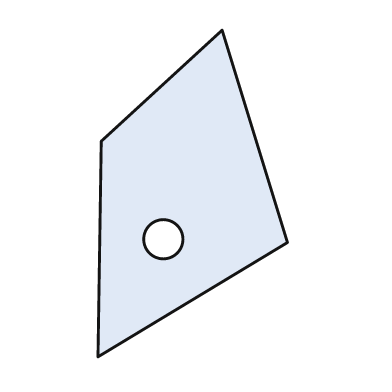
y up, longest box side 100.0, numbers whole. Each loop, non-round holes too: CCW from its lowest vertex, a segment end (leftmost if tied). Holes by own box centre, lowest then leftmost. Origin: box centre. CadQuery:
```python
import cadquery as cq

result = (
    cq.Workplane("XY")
    .moveTo(-29.0, -50.0)
    .lineTo(29.0, -15.0)
    .lineTo(9.0, 50.0)
    .lineTo(-28.0, 16.0)
    .close()
    .moveTo(-9.0, -14.0)
    .circle(6.0)
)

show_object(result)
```